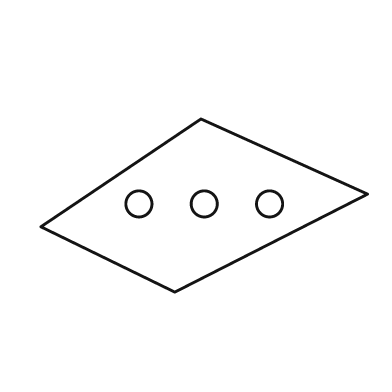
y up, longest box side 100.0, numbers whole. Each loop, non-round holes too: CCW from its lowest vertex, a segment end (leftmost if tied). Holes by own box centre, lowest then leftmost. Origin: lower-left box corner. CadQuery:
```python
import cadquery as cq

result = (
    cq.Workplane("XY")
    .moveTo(41.0, 0.0)
    .lineTo(100.0, 30.0)
    .lineTo(49.0, 53.0)
    .lineTo(0.0, 20.0)
    .close()
    .moveTo(30.0, 27.0)
    .circle(4.0)
    .moveTo(50.0, 27.0)
    .circle(4.0)
    .moveTo(70.0, 27.0)
    .circle(4.0)
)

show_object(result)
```